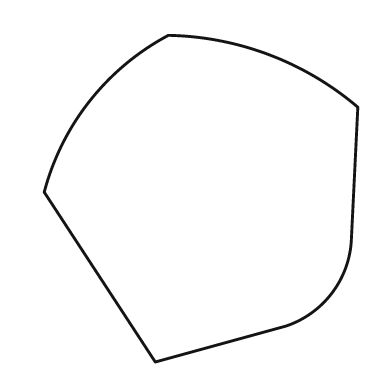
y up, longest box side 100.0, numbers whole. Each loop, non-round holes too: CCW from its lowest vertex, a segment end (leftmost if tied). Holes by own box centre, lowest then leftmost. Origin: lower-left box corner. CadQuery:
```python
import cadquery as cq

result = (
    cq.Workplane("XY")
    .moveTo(34.0, 0.0)
    .lineTo(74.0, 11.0)
    .threePointArc((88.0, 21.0), (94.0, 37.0))
    .lineTo(96.0, 78.0)
    .threePointArc((69.0, 94.0), (38.0, 100.0))
    .threePointArc((14.0, 80.0), (0.0, 52.0))
    .close()
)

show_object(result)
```